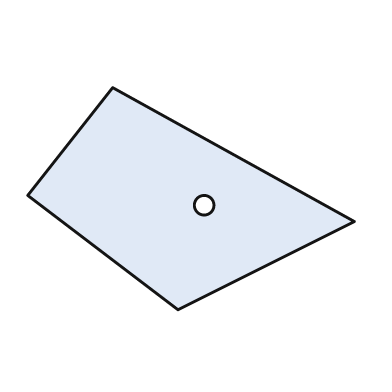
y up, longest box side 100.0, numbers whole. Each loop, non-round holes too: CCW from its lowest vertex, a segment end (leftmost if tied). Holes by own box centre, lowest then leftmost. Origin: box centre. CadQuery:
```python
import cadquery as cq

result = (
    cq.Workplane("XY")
    .moveTo(-4.0, -34.0)
    .lineTo(50.0, -7.0)
    .lineTo(-24.0, 34.0)
    .lineTo(-50.0, 1.0)
    .close()
    .moveTo(4.0, -2.0)
    .circle(3.0)
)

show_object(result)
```